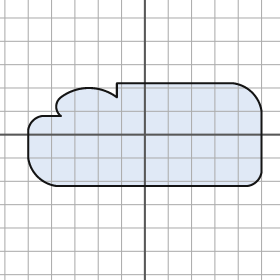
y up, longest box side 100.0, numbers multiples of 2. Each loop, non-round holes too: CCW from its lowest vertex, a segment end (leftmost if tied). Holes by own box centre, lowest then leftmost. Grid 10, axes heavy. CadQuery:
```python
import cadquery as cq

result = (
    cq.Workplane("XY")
    .moveTo(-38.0, -22.0)
    .lineTo(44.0, -22.0)
    .threePointArc((48.0, -20.0), (50.0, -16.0))
    .lineTo(50.0, 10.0)
    .threePointArc((46.0, 18.0), (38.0, 22.0))
    .lineTo(-12.0, 22.0)
    .lineTo(-12.0, 16.0)
    .threePointArc((-24.0, 20.0), (-36.0, 16.0))
    .threePointArc((-38.0, 12.0), (-36.0, 8.0))
    .lineTo(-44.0, 8.0)
    .threePointArc((-48.0, 6.0), (-50.0, 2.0))
    .lineTo(-50.0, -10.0)
    .threePointArc((-46.0, -18.0), (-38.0, -22.0))
    .close()
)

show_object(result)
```